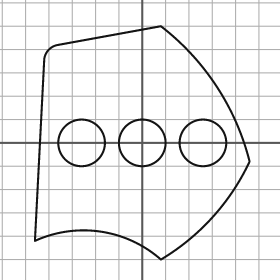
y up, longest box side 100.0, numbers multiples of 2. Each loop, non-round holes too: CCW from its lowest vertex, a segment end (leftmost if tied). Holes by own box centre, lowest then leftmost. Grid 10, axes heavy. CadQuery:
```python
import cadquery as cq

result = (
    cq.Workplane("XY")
    .moveTo(8.0, -50.0)
    .threePointArc((30.0, -32.0), (46.0, -8.0))
    .threePointArc((32.0, 24.0), (8.0, 50.0))
    .lineTo(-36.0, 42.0)
    .threePointArc((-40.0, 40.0), (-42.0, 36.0))
    .lineTo(-46.0, -42.0)
    .threePointArc((-18.0, -38.0), (8.0, -50.0))
    .close()
    .moveTo(-26.0, 0.0)
    .circle(10.0)
    .moveTo(0.0, 0.0)
    .circle(10.0)
    .moveTo(26.0, 0.0)
    .circle(10.0)
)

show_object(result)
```